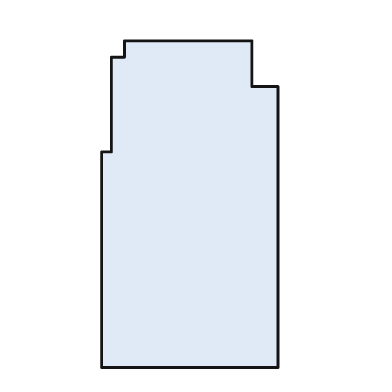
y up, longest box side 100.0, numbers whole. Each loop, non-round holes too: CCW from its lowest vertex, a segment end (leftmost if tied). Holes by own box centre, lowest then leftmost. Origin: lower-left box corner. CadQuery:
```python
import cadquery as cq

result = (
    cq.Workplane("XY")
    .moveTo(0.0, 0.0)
    .lineTo(54.0, 0.0)
    .lineTo(54.0, 86.0)
    .lineTo(46.0, 86.0)
    .lineTo(46.0, 100.0)
    .lineTo(7.0, 100.0)
    .lineTo(7.0, 95.0)
    .lineTo(3.0, 95.0)
    .lineTo(3.0, 66.0)
    .lineTo(0.0, 66.0)
    .close()
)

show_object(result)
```